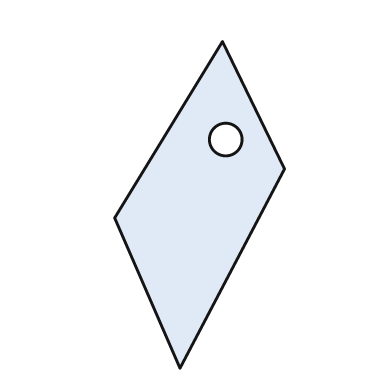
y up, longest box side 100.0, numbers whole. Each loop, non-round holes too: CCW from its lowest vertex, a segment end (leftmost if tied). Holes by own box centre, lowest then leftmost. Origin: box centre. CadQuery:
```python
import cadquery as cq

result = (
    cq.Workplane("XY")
    .moveTo(-6.0, -50.0)
    .lineTo(26.0, 11.0)
    .lineTo(7.0, 50.0)
    .lineTo(-26.0, -4.0)
    .close()
    .moveTo(8.0, 20.0)
    .circle(5.0)
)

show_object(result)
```